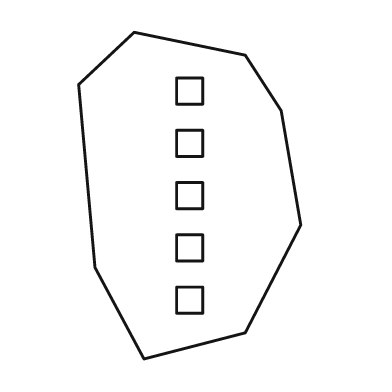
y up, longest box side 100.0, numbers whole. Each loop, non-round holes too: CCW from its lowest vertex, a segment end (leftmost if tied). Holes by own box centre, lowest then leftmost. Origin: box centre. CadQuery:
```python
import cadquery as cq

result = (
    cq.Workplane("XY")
    .moveTo(-14.0, -50.0)
    .lineTo(17.0, -42.0)
    .lineTo(34.0, -9.0)
    .lineTo(28.0, 26.0)
    .lineTo(17.0, 43.0)
    .lineTo(-17.0, 50.0)
    .lineTo(-34.0, 34.0)
    .lineTo(-29.0, -22.0)
    .close()
    .moveTo(-4.0, -36.0)
    .lineTo(4.0, -36.0)
    .lineTo(4.0, -28.0)
    .lineTo(-4.0, -28.0)
    .close()
    .moveTo(-4.0, -20.0)
    .lineTo(4.0, -20.0)
    .lineTo(4.0, -12.0)
    .lineTo(-4.0, -12.0)
    .close()
    .moveTo(-4.0, -4.0)
    .lineTo(4.0, -4.0)
    .lineTo(4.0, 4.0)
    .lineTo(-4.0, 4.0)
    .close()
    .moveTo(-4.0, 12.0)
    .lineTo(4.0, 12.0)
    .lineTo(4.0, 20.0)
    .lineTo(-4.0, 20.0)
    .close()
    .moveTo(-4.0, 28.0)
    .lineTo(4.0, 28.0)
    .lineTo(4.0, 36.0)
    .lineTo(-4.0, 36.0)
    .close()
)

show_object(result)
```